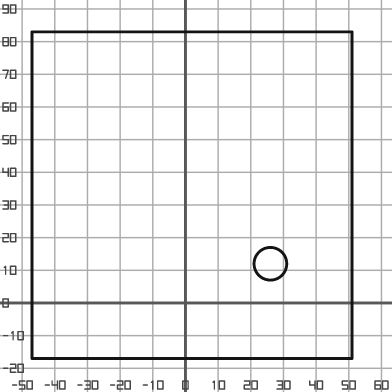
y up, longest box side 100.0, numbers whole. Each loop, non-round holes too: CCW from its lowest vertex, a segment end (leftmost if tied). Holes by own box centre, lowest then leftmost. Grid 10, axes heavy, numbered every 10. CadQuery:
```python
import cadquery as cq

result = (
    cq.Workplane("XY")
    .moveTo(-47.0, -17.0)
    .lineTo(51.0, -17.0)
    .lineTo(51.0, 83.0)
    .lineTo(-47.0, 83.0)
    .close()
    .moveTo(26.0, 12.0)
    .circle(5.0)
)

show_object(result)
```